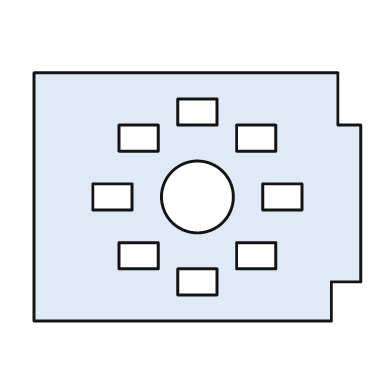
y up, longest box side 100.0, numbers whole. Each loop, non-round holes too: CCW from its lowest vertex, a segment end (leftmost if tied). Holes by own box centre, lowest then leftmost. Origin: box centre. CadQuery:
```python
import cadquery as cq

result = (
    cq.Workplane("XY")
    .moveTo(-50.0, -38.0)
    .lineTo(41.0, -38.0)
    .lineTo(41.0, -26.0)
    .lineTo(50.0, -26.0)
    .lineTo(50.0, 22.0)
    .lineTo(43.0, 22.0)
    .lineTo(43.0, 38.0)
    .lineTo(-50.0, 38.0)
    .close()
    .moveTo(-6.0, -30.0)
    .lineTo(6.0, -30.0)
    .lineTo(6.0, -22.0)
    .lineTo(-6.0, -22.0)
    .close()
    .moveTo(-24.0, -22.0)
    .lineTo(-12.0, -22.0)
    .lineTo(-12.0, -14.0)
    .lineTo(-24.0, -14.0)
    .close()
    .moveTo(12.0, -22.0)
    .lineTo(24.0, -22.0)
    .lineTo(24.0, -14.0)
    .lineTo(12.0, -14.0)
    .close()
    .moveTo(-32.0, -4.0)
    .lineTo(-20.0, -4.0)
    .lineTo(-20.0, 4.0)
    .lineTo(-32.0, 4.0)
    .close()
    .moveTo(0.0, 0.0)
    .circle(11.0)
    .moveTo(20.0, -4.0)
    .lineTo(32.0, -4.0)
    .lineTo(32.0, 4.0)
    .lineTo(20.0, 4.0)
    .close()
    .moveTo(-24.0, 14.0)
    .lineTo(-12.0, 14.0)
    .lineTo(-12.0, 22.0)
    .lineTo(-24.0, 22.0)
    .close()
    .moveTo(12.0, 14.0)
    .lineTo(24.0, 14.0)
    .lineTo(24.0, 22.0)
    .lineTo(12.0, 22.0)
    .close()
    .moveTo(-6.0, 22.0)
    .lineTo(6.0, 22.0)
    .lineTo(6.0, 30.0)
    .lineTo(-6.0, 30.0)
    .close()
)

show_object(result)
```